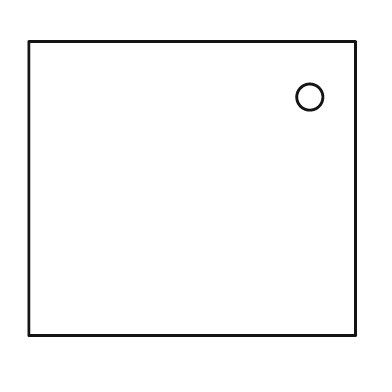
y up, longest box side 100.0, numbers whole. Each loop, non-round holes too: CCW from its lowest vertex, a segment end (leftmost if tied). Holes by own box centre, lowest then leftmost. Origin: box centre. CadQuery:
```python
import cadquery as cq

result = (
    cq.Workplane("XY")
    .moveTo(-50.0, -45.0)
    .lineTo(50.0, -45.0)
    .lineTo(50.0, 45.0)
    .lineTo(-50.0, 45.0)
    .close()
    .moveTo(36.0, 28.0)
    .circle(4.0)
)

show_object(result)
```